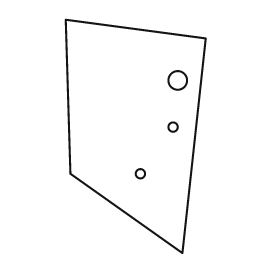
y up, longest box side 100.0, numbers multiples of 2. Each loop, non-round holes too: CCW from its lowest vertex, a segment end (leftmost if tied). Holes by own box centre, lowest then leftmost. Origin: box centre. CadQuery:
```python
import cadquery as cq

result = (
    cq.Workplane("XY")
    .moveTo(20.0, -50.0)
    .lineTo(30.0, 42.0)
    .lineTo(-30.0, 50.0)
    .lineTo(-28.0, -16.0)
    .close()
    .moveTo(2.0, -16.0)
    .circle(2.0)
    .moveTo(16.0, 4.0)
    .circle(2.0)
    .moveTo(18.0, 24.0)
    .circle(4.0)
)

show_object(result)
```